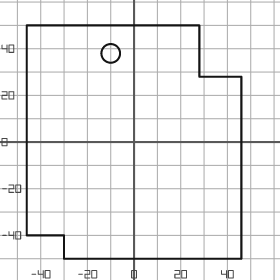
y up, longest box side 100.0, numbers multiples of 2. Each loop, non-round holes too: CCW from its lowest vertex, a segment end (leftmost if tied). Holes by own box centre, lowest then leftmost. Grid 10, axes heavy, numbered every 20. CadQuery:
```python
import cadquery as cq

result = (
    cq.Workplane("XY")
    .moveTo(-30.0, -50.0)
    .lineTo(46.0, -50.0)
    .lineTo(46.0, 28.0)
    .lineTo(28.0, 28.0)
    .lineTo(28.0, 50.0)
    .lineTo(-46.0, 50.0)
    .lineTo(-46.0, -40.0)
    .lineTo(-30.0, -40.0)
    .close()
    .moveTo(-10.0, 38.0)
    .circle(4.0)
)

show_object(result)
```